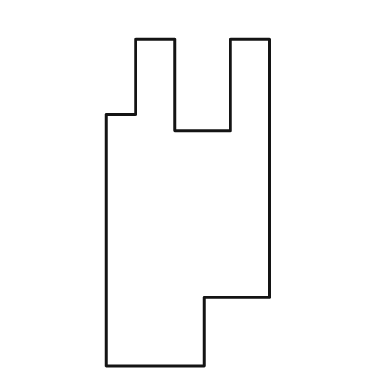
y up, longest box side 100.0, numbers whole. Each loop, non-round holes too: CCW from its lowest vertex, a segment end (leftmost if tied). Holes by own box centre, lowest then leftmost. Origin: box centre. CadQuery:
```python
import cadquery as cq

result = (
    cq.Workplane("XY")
    .moveTo(-25.0, -50.0)
    .lineTo(5.0, -50.0)
    .lineTo(5.0, -29.0)
    .lineTo(25.0, -29.0)
    .lineTo(25.0, 50.0)
    .lineTo(13.0, 50.0)
    .lineTo(13.0, 22.0)
    .lineTo(-4.0, 22.0)
    .lineTo(-4.0, 50.0)
    .lineTo(-16.0, 50.0)
    .lineTo(-16.0, 27.0)
    .lineTo(-25.0, 27.0)
    .close()
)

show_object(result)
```